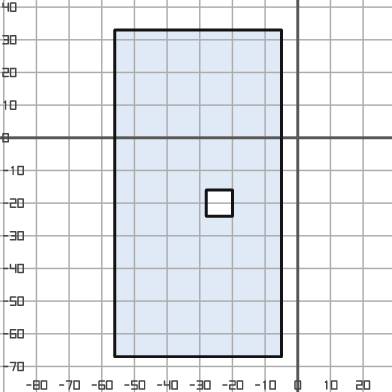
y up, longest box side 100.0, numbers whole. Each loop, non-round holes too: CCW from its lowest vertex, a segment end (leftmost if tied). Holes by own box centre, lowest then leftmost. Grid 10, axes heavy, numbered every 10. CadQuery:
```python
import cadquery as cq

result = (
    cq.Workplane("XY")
    .moveTo(-56.0, -67.0)
    .lineTo(-5.0, -67.0)
    .lineTo(-5.0, 33.0)
    .lineTo(-56.0, 33.0)
    .close()
    .moveTo(-28.0, -24.0)
    .lineTo(-20.0, -24.0)
    .lineTo(-20.0, -16.0)
    .lineTo(-28.0, -16.0)
    .close()
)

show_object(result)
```